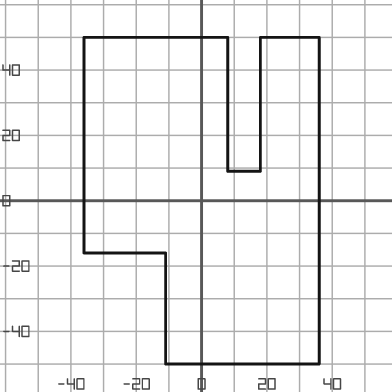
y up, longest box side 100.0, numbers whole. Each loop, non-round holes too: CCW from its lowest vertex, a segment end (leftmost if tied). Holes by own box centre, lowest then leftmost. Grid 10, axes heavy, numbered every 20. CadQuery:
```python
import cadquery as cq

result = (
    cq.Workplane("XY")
    .moveTo(-11.0, -50.0)
    .lineTo(36.0, -50.0)
    .lineTo(36.0, 50.0)
    .lineTo(18.0, 50.0)
    .lineTo(18.0, 9.0)
    .lineTo(8.0, 9.0)
    .lineTo(8.0, 50.0)
    .lineTo(-36.0, 50.0)
    .lineTo(-36.0, -16.0)
    .lineTo(-11.0, -16.0)
    .close()
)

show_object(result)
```